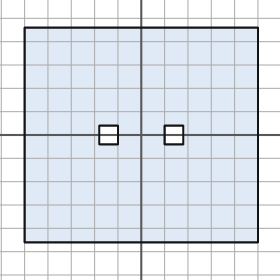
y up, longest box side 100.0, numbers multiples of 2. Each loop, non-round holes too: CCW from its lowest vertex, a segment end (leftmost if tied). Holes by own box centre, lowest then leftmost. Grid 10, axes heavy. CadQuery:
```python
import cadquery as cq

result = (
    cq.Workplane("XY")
    .moveTo(-50.0, -46.0)
    .lineTo(50.0, -46.0)
    .lineTo(50.0, 46.0)
    .lineTo(-50.0, 46.0)
    .close()
    .moveTo(-18.0, -4.0)
    .lineTo(-10.0, -4.0)
    .lineTo(-10.0, 4.0)
    .lineTo(-18.0, 4.0)
    .close()
    .moveTo(10.0, -4.0)
    .lineTo(18.0, -4.0)
    .lineTo(18.0, 4.0)
    .lineTo(10.0, 4.0)
    .close()
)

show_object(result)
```